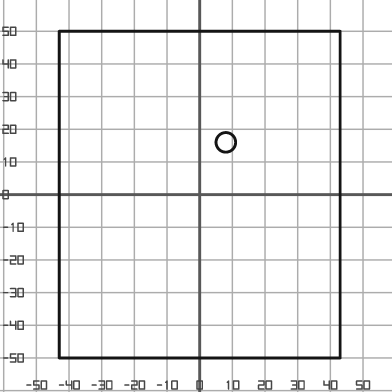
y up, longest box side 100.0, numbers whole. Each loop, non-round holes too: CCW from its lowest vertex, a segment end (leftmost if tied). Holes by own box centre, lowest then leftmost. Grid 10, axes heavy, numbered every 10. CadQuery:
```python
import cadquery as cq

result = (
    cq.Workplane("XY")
    .moveTo(-43.0, -50.0)
    .lineTo(43.0, -50.0)
    .lineTo(43.0, 50.0)
    .lineTo(-43.0, 50.0)
    .close()
    .moveTo(8.0, 16.0)
    .circle(3.0)
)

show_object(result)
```